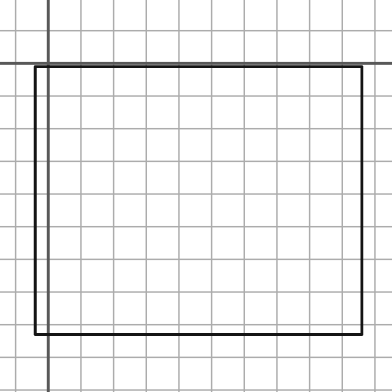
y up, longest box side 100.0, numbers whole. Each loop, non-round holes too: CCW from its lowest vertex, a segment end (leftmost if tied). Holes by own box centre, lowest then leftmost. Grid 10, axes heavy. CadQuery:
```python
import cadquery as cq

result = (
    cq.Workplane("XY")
    .moveTo(-4.0, -83.0)
    .lineTo(96.0, -83.0)
    .lineTo(96.0, -1.0)
    .lineTo(-4.0, -1.0)
    .close()
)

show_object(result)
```